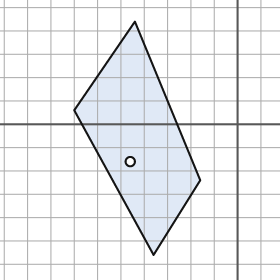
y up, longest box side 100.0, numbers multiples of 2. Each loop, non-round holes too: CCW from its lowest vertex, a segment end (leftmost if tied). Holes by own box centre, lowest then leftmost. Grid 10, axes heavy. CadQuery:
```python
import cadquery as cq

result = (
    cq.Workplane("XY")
    .moveTo(-36.0, -56.0)
    .lineTo(-16.0, -24.0)
    .lineTo(-44.0, 44.0)
    .lineTo(-70.0, 6.0)
    .close()
    .moveTo(-46.0, -16.0)
    .circle(2.0)
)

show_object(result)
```